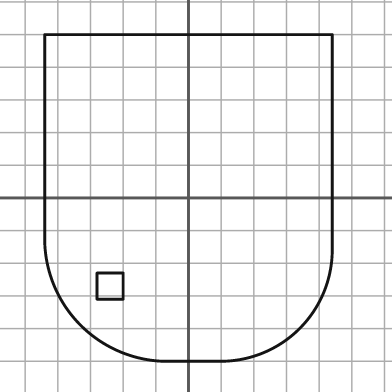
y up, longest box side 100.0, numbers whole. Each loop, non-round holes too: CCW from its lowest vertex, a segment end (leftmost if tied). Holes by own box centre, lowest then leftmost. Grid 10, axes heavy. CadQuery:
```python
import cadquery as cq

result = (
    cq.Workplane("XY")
    .moveTo(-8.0, -50.0)
    .lineTo(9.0, -50.0)
    .threePointArc((34.0, -40.0), (44.0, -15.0))
    .lineTo(44.0, 50.0)
    .lineTo(-44.0, 50.0)
    .lineTo(-44.0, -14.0)
    .threePointArc((-33.0, -39.0), (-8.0, -50.0))
    .close()
    .moveTo(-28.0, -31.0)
    .lineTo(-20.0, -31.0)
    .lineTo(-20.0, -23.0)
    .lineTo(-28.0, -23.0)
    .close()
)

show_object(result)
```